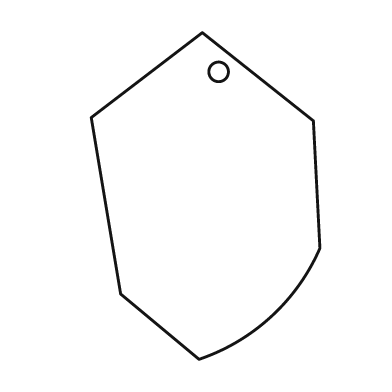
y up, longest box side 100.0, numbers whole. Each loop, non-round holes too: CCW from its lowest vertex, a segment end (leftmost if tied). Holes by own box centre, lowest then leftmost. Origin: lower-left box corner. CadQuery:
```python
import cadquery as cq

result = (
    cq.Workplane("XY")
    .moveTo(33.0, 0.0)
    .threePointArc((55.0, 13.0), (70.0, 34.0))
    .lineTo(68.0, 73.0)
    .lineTo(34.0, 100.0)
    .lineTo(0.0, 74.0)
    .lineTo(9.0, 20.0)
    .close()
    .moveTo(39.0, 88.0)
    .circle(3.0)
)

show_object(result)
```